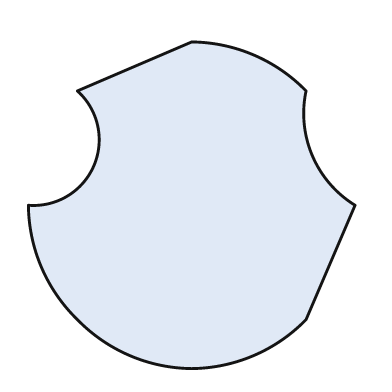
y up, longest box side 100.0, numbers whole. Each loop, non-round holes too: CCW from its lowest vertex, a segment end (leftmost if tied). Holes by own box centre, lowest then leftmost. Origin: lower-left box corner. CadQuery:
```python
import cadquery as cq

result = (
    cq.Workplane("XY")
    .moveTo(50.0, 0.0)
    .threePointArc((69.0, 4.0), (85.0, 15.0))
    .lineTo(100.0, 50.0)
    .threePointArc((87.0, 65.0), (85.0, 85.0))
    .threePointArc((69.0, 96.0), (50.0, 100.0))
    .lineTo(15.0, 85.0)
    .threePointArc((20.0, 62.0), (0.0, 50.0))
    .threePointArc((4.0, 31.0), (15.0, 15.0))
    .threePointArc((31.0, 4.0), (50.0, 0.0))
    .close()
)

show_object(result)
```